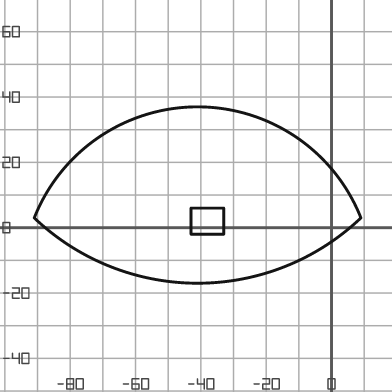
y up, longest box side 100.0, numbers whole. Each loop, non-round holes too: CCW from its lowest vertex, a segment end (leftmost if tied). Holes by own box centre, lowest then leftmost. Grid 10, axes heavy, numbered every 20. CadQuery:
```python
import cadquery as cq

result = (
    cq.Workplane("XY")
    .moveTo(-91.0, 3.0)
    .threePointArc((-41.0, -17.0), (9.0, 3.0))
    .threePointArc((-41.0, 37.0), (-91.0, 3.0))
    .close()
    .moveTo(-43.0, -2.0)
    .lineTo(-33.0, -2.0)
    .lineTo(-33.0, 6.0)
    .lineTo(-43.0, 6.0)
    .close()
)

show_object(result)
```